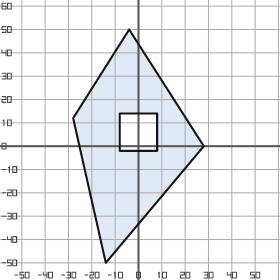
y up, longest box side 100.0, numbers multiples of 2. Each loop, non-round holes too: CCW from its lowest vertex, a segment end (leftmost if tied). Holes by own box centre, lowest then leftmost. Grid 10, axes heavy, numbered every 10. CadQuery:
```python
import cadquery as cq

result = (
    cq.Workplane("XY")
    .moveTo(-14.0, -50.0)
    .lineTo(28.0, 0.0)
    .lineTo(-4.0, 50.0)
    .lineTo(-28.0, 12.0)
    .close()
    .moveTo(-8.0, -2.0)
    .lineTo(8.0, -2.0)
    .lineTo(8.0, 14.0)
    .lineTo(-8.0, 14.0)
    .close()
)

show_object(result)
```